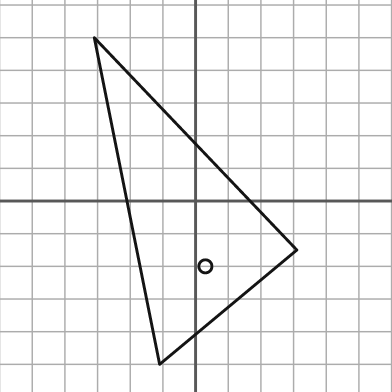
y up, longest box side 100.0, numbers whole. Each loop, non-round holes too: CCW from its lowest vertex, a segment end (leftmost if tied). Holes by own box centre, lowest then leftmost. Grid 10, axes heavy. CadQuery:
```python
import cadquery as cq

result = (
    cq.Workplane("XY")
    .moveTo(-11.0, -50.0)
    .lineTo(31.0, -15.0)
    .lineTo(-31.0, 50.0)
    .close()
    .moveTo(3.0, -20.0)
    .circle(2.0)
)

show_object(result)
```